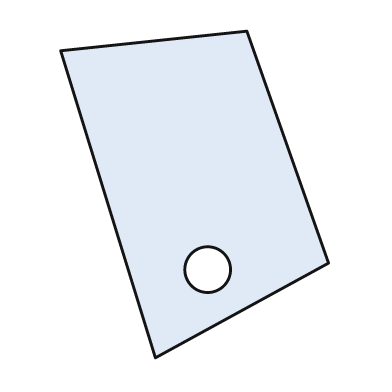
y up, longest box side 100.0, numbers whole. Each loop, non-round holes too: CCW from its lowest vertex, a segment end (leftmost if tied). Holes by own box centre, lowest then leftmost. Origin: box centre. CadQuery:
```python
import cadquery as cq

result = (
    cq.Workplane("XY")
    .moveTo(-12.0, -50.0)
    .lineTo(41.0, -21.0)
    .lineTo(16.0, 50.0)
    .lineTo(-41.0, 44.0)
    .close()
    .moveTo(4.0, -23.0)
    .circle(7.0)
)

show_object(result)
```